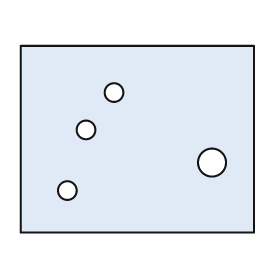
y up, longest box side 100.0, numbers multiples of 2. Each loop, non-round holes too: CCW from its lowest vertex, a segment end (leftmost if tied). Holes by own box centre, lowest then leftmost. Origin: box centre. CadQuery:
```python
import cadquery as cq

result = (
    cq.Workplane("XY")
    .moveTo(-50.0, -40.0)
    .lineTo(50.0, -40.0)
    .lineTo(50.0, 40.0)
    .lineTo(-50.0, 40.0)
    .close()
    .moveTo(-30.0, -22.0)
    .circle(4.0)
    .moveTo(32.0, -10.0)
    .circle(6.0)
    .moveTo(-22.0, 4.0)
    .circle(4.0)
    .moveTo(-10.0, 20.0)
    .circle(4.0)
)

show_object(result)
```